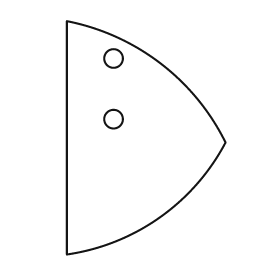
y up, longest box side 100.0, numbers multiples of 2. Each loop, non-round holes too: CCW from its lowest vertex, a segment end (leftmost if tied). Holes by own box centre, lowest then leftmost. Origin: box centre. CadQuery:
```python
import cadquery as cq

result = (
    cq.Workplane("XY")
    .moveTo(-34.0, -50.0)
    .threePointArc((6.0, -34.0), (34.0, -2.0))
    .threePointArc((6.0, 32.0), (-34.0, 50.0))
    .close()
    .moveTo(-14.0, 8.0)
    .circle(4.0)
    .moveTo(-14.0, 34.0)
    .circle(4.0)
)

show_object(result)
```